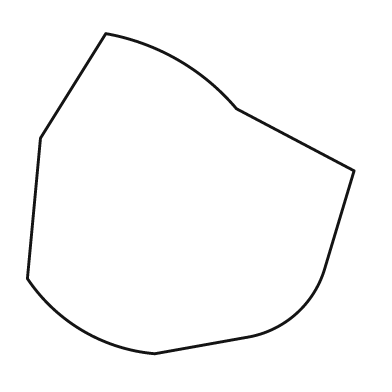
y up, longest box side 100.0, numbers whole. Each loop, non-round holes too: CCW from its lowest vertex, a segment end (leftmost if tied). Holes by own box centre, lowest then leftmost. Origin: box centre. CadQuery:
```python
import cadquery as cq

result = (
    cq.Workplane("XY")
    .moveTo(-11.0, -49.0)
    .lineTo(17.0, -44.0)
    .threePointArc((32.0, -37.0), (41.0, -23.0))
    .lineTo(50.0, 7.0)
    .lineTo(14.0, 26.0)
    .threePointArc((-4.0, 41.0), (-26.0, 49.0))
    .lineTo(-46.0, 17.0)
    .lineTo(-50.0, -26.0)
    .threePointArc((-33.0, -42.0), (-11.0, -49.0))
    .close()
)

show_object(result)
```